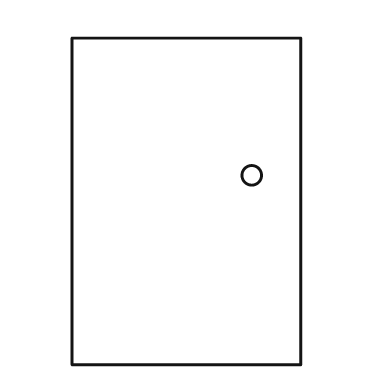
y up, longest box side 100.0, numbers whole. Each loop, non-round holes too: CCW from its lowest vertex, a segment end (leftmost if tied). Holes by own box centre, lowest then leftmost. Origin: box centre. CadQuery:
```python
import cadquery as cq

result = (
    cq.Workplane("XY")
    .moveTo(-35.0, -50.0)
    .lineTo(35.0, -50.0)
    .lineTo(35.0, 50.0)
    .lineTo(-35.0, 50.0)
    .close()
    .moveTo(20.0, 8.0)
    .circle(3.0)
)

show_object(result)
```